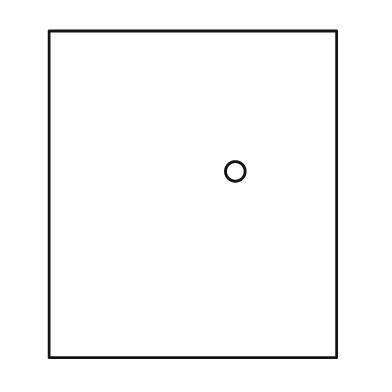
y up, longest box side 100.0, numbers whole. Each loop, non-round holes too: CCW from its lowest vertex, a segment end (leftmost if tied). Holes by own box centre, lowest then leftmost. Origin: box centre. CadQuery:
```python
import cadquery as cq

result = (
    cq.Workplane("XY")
    .moveTo(-44.0, -50.0)
    .lineTo(44.0, -50.0)
    .lineTo(44.0, 50.0)
    .lineTo(-44.0, 50.0)
    .close()
    .moveTo(13.0, 7.0)
    .circle(3.0)
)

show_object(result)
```